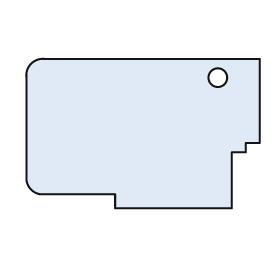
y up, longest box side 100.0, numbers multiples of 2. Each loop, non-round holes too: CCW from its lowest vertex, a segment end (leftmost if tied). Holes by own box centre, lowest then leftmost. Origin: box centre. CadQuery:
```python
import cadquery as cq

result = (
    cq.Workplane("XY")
    .moveTo(-12.0, -32.0)
    .lineTo(38.0, -32.0)
    .lineTo(38.0, -8.0)
    .lineTo(44.0, -8.0)
    .lineTo(44.0, -4.0)
    .lineTo(50.0, -4.0)
    .lineTo(50.0, 32.0)
    .lineTo(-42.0, 32.0)
    .threePointArc((-48.0, 30.0), (-50.0, 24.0))
    .lineTo(-50.0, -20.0)
    .threePointArc((-48.0, -24.0), (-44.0, -26.0))
    .lineTo(-12.0, -26.0)
    .close()
    .moveTo(32.0, 24.0)
    .circle(4.0)
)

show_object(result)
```